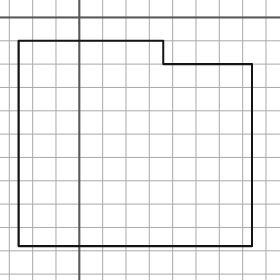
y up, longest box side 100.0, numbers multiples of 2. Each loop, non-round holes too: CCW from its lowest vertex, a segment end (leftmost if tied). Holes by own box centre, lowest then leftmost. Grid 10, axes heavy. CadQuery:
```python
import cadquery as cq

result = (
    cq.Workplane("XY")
    .moveTo(-26.0, -98.0)
    .lineTo(74.0, -98.0)
    .lineTo(74.0, -20.0)
    .lineTo(36.0, -20.0)
    .lineTo(36.0, -10.0)
    .lineTo(-26.0, -10.0)
    .close()
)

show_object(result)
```